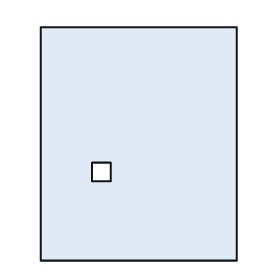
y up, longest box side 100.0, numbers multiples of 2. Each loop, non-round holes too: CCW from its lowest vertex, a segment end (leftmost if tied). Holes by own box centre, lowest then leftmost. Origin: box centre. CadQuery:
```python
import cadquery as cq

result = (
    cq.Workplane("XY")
    .moveTo(-42.0, -50.0)
    .lineTo(42.0, -50.0)
    .lineTo(42.0, 50.0)
    .lineTo(-42.0, 50.0)
    .close()
    .moveTo(-20.0, -16.0)
    .lineTo(-12.0, -16.0)
    .lineTo(-12.0, -8.0)
    .lineTo(-20.0, -8.0)
    .close()
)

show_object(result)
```